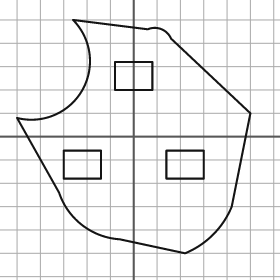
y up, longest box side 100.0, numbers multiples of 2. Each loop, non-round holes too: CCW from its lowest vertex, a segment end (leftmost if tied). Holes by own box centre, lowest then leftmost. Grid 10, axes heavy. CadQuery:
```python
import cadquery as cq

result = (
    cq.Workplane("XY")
    .moveTo(22.0, -50.0)
    .threePointArc((34.0, -42.0), (42.0, -30.0))
    .lineTo(50.0, 10.0)
    .lineTo(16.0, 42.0)
    .threePointArc((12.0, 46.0), (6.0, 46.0))
    .lineTo(-26.0, 50.0)
    .threePointArc((-22.0, 20.0), (-50.0, 8.0))
    .lineTo(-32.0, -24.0)
    .threePointArc((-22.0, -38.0), (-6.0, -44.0))
    .close()
    .moveTo(-30.0, -18.0)
    .lineTo(-14.0, -18.0)
    .lineTo(-14.0, -6.0)
    .lineTo(-30.0, -6.0)
    .close()
    .moveTo(14.0, -18.0)
    .lineTo(30.0, -18.0)
    .lineTo(30.0, -6.0)
    .lineTo(14.0, -6.0)
    .close()
    .moveTo(-8.0, 20.0)
    .lineTo(8.0, 20.0)
    .lineTo(8.0, 32.0)
    .lineTo(-8.0, 32.0)
    .close()
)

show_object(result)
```